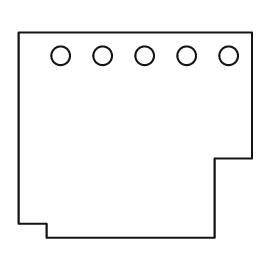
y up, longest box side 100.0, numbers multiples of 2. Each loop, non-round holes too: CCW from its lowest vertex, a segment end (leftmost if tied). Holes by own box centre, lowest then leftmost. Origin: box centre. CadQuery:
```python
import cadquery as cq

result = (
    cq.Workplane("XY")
    .moveTo(-38.0, -44.0)
    .lineTo(34.0, -44.0)
    .lineTo(34.0, -10.0)
    .lineTo(50.0, -10.0)
    .lineTo(50.0, 44.0)
    .lineTo(-50.0, 44.0)
    .lineTo(-50.0, -38.0)
    .lineTo(-38.0, -38.0)
    .close()
    .moveTo(-32.0, 34.0)
    .circle(4.0)
    .moveTo(-14.0, 34.0)
    .circle(4.0)
    .moveTo(4.0, 34.0)
    .circle(4.0)
    .moveTo(22.0, 34.0)
    .circle(4.0)
    .moveTo(40.0, 34.0)
    .circle(4.0)
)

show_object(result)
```